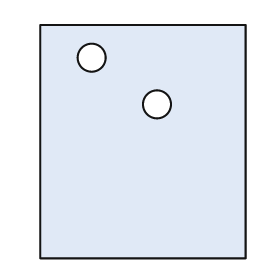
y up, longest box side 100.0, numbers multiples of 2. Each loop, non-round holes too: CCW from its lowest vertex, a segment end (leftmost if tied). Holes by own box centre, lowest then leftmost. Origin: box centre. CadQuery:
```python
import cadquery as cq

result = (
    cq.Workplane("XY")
    .moveTo(-44.0, -50.0)
    .lineTo(44.0, -50.0)
    .lineTo(44.0, 50.0)
    .lineTo(-44.0, 50.0)
    .close()
    .moveTo(6.0, 16.0)
    .circle(6.0)
    .moveTo(-22.0, 36.0)
    .circle(6.0)
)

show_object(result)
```